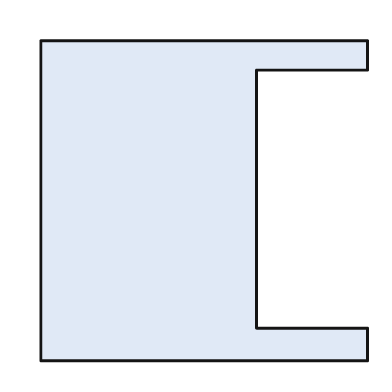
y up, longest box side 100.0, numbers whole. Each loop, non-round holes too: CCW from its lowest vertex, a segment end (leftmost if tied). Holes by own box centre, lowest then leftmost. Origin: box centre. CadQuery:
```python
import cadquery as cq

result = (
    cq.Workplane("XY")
    .moveTo(-50.0, -49.0)
    .lineTo(50.0, -49.0)
    .lineTo(50.0, -39.0)
    .lineTo(16.0, -39.0)
    .lineTo(16.0, 40.0)
    .lineTo(50.0, 40.0)
    .lineTo(50.0, 49.0)
    .lineTo(-50.0, 49.0)
    .close()
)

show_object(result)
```